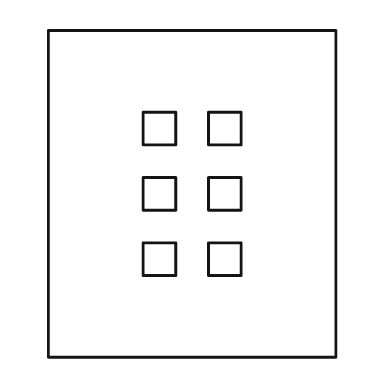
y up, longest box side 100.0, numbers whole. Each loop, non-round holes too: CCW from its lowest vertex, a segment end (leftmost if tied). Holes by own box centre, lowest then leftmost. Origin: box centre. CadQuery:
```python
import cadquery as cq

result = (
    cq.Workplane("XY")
    .moveTo(-44.0, -50.0)
    .lineTo(44.0, -50.0)
    .lineTo(44.0, 50.0)
    .lineTo(-44.0, 50.0)
    .close()
    .moveTo(-15.0, -25.0)
    .lineTo(-5.0, -25.0)
    .lineTo(-5.0, -15.0)
    .lineTo(-15.0, -15.0)
    .close()
    .moveTo(5.0, -25.0)
    .lineTo(15.0, -25.0)
    .lineTo(15.0, -15.0)
    .lineTo(5.0, -15.0)
    .close()
    .moveTo(-15.0, -5.0)
    .lineTo(-5.0, -5.0)
    .lineTo(-5.0, 5.0)
    .lineTo(-15.0, 5.0)
    .close()
    .moveTo(5.0, -5.0)
    .lineTo(15.0, -5.0)
    .lineTo(15.0, 5.0)
    .lineTo(5.0, 5.0)
    .close()
    .moveTo(-15.0, 15.0)
    .lineTo(-5.0, 15.0)
    .lineTo(-5.0, 25.0)
    .lineTo(-15.0, 25.0)
    .close()
    .moveTo(5.0, 15.0)
    .lineTo(15.0, 15.0)
    .lineTo(15.0, 25.0)
    .lineTo(5.0, 25.0)
    .close()
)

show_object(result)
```